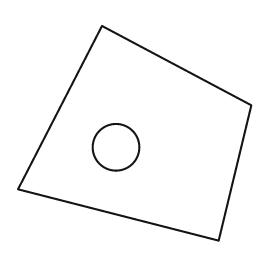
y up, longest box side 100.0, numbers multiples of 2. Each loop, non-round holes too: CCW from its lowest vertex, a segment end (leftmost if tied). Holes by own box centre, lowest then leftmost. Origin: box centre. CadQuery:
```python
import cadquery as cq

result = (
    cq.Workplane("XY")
    .moveTo(36.0, -46.0)
    .lineTo(50.0, 12.0)
    .lineTo(-14.0, 46.0)
    .lineTo(-50.0, -24.0)
    .close()
    .moveTo(-8.0, -6.0)
    .circle(10.0)
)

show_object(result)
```